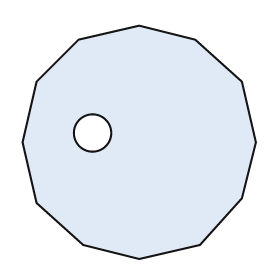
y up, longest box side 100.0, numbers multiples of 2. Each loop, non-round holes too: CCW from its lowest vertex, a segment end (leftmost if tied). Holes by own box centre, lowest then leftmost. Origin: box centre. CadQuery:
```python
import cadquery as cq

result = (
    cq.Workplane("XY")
    .moveTo(0.0, -50.0)
    .lineTo(26.0, -44.0)
    .lineTo(44.0, -24.0)
    .lineTo(50.0, 0.0)
    .lineTo(44.0, 26.0)
    .lineTo(24.0, 44.0)
    .lineTo(0.0, 50.0)
    .lineTo(-26.0, 44.0)
    .lineTo(-44.0, 26.0)
    .lineTo(-50.0, 0.0)
    .lineTo(-44.0, -26.0)
    .lineTo(-24.0, -44.0)
    .close()
    .moveTo(-20.0, 4.0)
    .circle(8.0)
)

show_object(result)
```